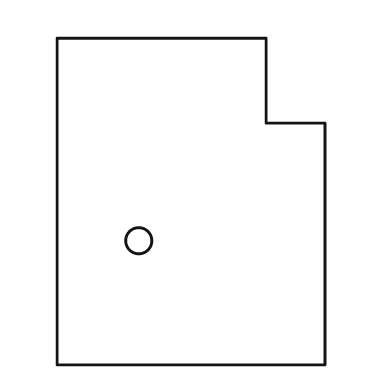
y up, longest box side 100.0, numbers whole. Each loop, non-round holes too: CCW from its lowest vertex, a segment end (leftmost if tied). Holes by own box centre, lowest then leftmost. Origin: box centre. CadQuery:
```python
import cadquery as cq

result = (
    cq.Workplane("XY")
    .moveTo(-41.0, -50.0)
    .lineTo(41.0, -50.0)
    .lineTo(41.0, 24.0)
    .lineTo(23.0, 24.0)
    .lineTo(23.0, 50.0)
    .lineTo(-41.0, 50.0)
    .close()
    .moveTo(-16.0, -12.0)
    .circle(4.0)
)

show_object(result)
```